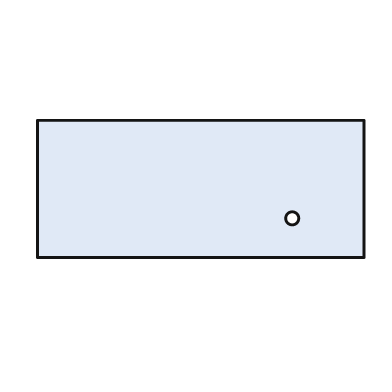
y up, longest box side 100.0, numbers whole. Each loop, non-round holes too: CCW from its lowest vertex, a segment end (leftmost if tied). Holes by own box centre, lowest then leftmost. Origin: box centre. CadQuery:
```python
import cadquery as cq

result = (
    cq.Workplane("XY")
    .moveTo(-50.0, -21.0)
    .lineTo(50.0, -21.0)
    .lineTo(50.0, 21.0)
    .lineTo(-50.0, 21.0)
    .close()
    .moveTo(28.0, -9.0)
    .circle(2.0)
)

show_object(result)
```